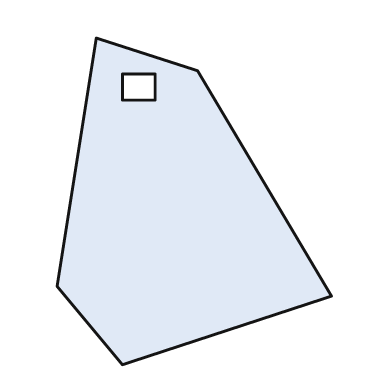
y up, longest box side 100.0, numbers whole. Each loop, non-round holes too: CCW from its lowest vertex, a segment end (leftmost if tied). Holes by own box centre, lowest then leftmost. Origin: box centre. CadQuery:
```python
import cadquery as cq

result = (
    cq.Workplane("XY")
    .moveTo(-22.0, -50.0)
    .lineTo(42.0, -29.0)
    .lineTo(1.0, 40.0)
    .lineTo(-30.0, 50.0)
    .lineTo(-42.0, -26.0)
    .close()
    .moveTo(-22.0, 31.0)
    .lineTo(-12.0, 31.0)
    .lineTo(-12.0, 39.0)
    .lineTo(-22.0, 39.0)
    .close()
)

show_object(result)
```